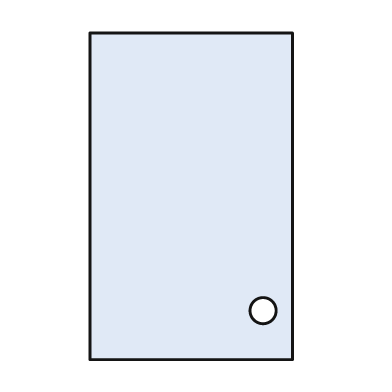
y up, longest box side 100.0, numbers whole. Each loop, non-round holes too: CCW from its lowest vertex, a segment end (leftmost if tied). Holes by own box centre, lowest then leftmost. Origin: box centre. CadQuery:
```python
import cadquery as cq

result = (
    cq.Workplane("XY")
    .moveTo(-31.0, -50.0)
    .lineTo(31.0, -50.0)
    .lineTo(31.0, 50.0)
    .lineTo(-31.0, 50.0)
    .close()
    .moveTo(22.0, -35.0)
    .circle(4.0)
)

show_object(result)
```